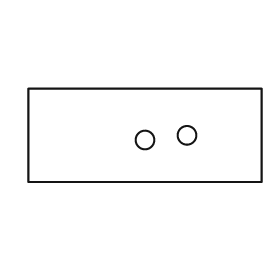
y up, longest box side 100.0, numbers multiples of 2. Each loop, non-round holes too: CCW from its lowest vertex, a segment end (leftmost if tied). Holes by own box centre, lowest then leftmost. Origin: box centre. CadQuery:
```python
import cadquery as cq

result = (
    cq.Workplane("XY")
    .moveTo(-50.0, -20.0)
    .lineTo(50.0, -20.0)
    .lineTo(50.0, 20.0)
    .lineTo(-50.0, 20.0)
    .close()
    .moveTo(0.0, -2.0)
    .circle(4.0)
    .moveTo(18.0, 0.0)
    .circle(4.0)
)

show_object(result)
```